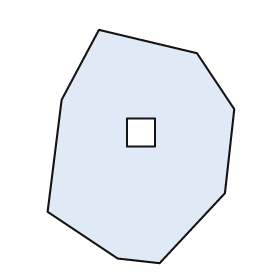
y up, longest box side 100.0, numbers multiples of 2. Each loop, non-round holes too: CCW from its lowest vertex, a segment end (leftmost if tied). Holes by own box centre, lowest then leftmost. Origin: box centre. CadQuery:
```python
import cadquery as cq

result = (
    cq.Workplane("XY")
    .moveTo(8.0, -50.0)
    .lineTo(36.0, -20.0)
    .lineTo(40.0, 16.0)
    .lineTo(24.0, 40.0)
    .lineTo(-18.0, 50.0)
    .lineTo(-34.0, 20.0)
    .lineTo(-40.0, -28.0)
    .lineTo(-10.0, -48.0)
    .close()
    .moveTo(-6.0, 0.0)
    .lineTo(6.0, 0.0)
    .lineTo(6.0, 12.0)
    .lineTo(-6.0, 12.0)
    .close()
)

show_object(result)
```